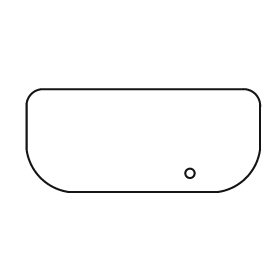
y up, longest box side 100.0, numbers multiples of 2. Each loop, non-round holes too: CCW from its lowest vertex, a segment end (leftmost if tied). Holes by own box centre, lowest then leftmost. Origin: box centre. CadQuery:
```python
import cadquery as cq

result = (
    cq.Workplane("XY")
    .moveTo(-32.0, -22.0)
    .lineTo(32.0, -22.0)
    .threePointArc((44.0, -16.0), (50.0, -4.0))
    .lineTo(50.0, 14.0)
    .threePointArc((48.0, 20.0), (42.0, 22.0))
    .lineTo(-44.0, 22.0)
    .threePointArc((-48.0, 20.0), (-50.0, 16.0))
    .lineTo(-50.0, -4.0)
    .threePointArc((-44.0, -16.0), (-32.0, -22.0))
    .close()
    .moveTo(20.0, -14.0)
    .circle(2.0)
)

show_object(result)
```